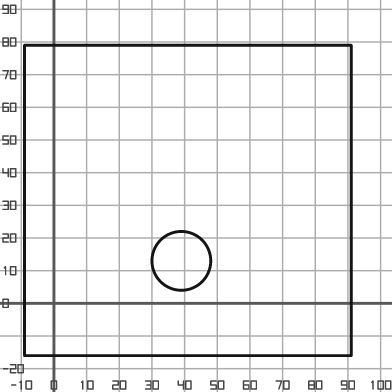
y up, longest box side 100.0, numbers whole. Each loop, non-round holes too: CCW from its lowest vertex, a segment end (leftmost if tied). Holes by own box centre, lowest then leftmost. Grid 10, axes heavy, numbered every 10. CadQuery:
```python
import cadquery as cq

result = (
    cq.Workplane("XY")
    .moveTo(-9.0, -16.0)
    .lineTo(91.0, -16.0)
    .lineTo(91.0, 79.0)
    .lineTo(-9.0, 79.0)
    .close()
    .moveTo(39.0, 13.0)
    .circle(9.0)
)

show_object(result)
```